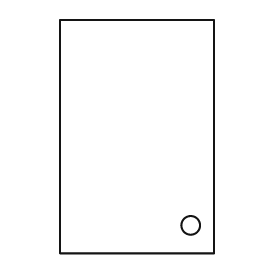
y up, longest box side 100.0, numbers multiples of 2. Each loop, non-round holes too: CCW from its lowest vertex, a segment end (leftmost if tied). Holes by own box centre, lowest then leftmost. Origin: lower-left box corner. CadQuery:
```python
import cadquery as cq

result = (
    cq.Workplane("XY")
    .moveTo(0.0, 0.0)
    .lineTo(66.0, 0.0)
    .lineTo(66.0, 100.0)
    .lineTo(0.0, 100.0)
    .close()
    .moveTo(56.0, 12.0)
    .circle(4.0)
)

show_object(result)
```